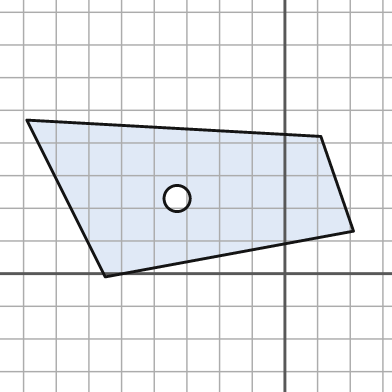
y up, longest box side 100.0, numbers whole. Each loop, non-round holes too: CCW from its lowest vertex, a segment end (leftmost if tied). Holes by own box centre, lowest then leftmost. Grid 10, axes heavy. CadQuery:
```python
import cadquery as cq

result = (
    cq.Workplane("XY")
    .moveTo(-55.0, -1.0)
    .lineTo(21.0, 13.0)
    .lineTo(11.0, 42.0)
    .lineTo(-79.0, 47.0)
    .close()
    .moveTo(-33.0, 23.0)
    .circle(4.0)
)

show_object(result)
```